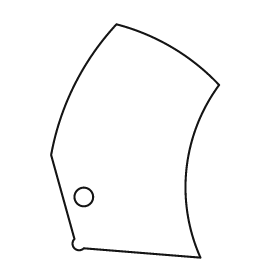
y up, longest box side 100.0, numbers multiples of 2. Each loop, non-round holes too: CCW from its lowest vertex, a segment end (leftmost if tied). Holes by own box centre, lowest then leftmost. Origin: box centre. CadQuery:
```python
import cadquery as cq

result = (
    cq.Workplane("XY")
    .moveTo(28.0, -50.0)
    .threePointArc((22.0, -12.0), (36.0, 24.0))
    .threePointArc((16.0, 40.0), (-8.0, 50.0))
    .threePointArc((-26.0, 24.0), (-36.0, -6.0))
    .lineTo(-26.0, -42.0)
    .threePointArc((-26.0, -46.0), (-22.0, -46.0))
    .close()
    .moveTo(-22.0, -24.0)
    .circle(4.0)
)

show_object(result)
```